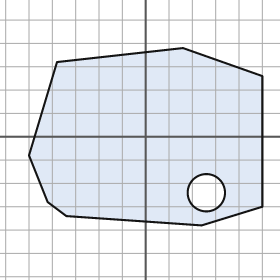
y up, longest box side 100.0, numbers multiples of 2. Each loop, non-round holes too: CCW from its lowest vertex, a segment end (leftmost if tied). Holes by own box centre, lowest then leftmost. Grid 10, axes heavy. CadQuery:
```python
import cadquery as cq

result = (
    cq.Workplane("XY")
    .moveTo(24.0, -38.0)
    .lineTo(50.0, -30.0)
    .lineTo(50.0, 26.0)
    .lineTo(16.0, 38.0)
    .lineTo(-38.0, 32.0)
    .lineTo(-50.0, -8.0)
    .lineTo(-42.0, -28.0)
    .lineTo(-34.0, -34.0)
    .close()
    .moveTo(26.0, -24.0)
    .circle(8.0)
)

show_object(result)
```